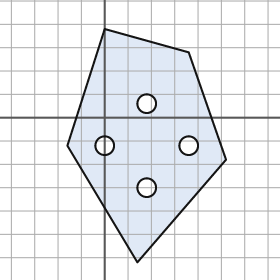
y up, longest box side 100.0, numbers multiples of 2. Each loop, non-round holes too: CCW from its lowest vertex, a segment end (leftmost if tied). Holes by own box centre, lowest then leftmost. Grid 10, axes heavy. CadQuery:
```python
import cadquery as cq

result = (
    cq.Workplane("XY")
    .moveTo(14.0, -62.0)
    .lineTo(52.0, -18.0)
    .lineTo(36.0, 28.0)
    .lineTo(0.0, 38.0)
    .lineTo(-16.0, -12.0)
    .close()
    .moveTo(18.0, -30.0)
    .circle(4.0)
    .moveTo(0.0, -12.0)
    .circle(4.0)
    .moveTo(36.0, -12.0)
    .circle(4.0)
    .moveTo(18.0, 6.0)
    .circle(4.0)
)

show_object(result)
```